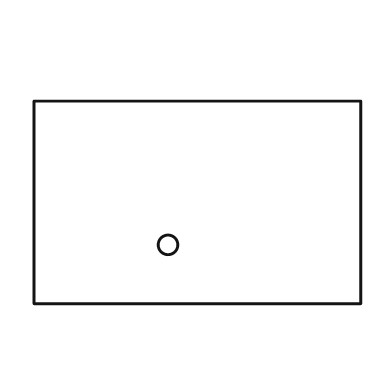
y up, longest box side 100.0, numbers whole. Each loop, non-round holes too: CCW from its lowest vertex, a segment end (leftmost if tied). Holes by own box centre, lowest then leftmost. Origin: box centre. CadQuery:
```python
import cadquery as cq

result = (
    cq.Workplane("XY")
    .moveTo(-50.0, -31.0)
    .lineTo(50.0, -31.0)
    .lineTo(50.0, 31.0)
    .lineTo(-50.0, 31.0)
    .close()
    .moveTo(-9.0, -13.0)
    .circle(3.0)
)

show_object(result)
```